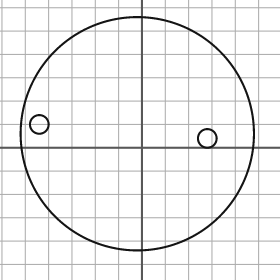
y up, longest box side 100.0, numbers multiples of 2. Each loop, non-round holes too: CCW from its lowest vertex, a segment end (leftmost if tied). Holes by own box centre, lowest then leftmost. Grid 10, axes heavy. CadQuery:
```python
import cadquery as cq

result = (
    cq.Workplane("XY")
    .moveTo(-2.0, 6.0)
    .circle(50.0)
    .moveTo(28.0, 4.0)
    .circle(4.0)
    .moveTo(-44.0, 10.0)
    .circle(4.0)
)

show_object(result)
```